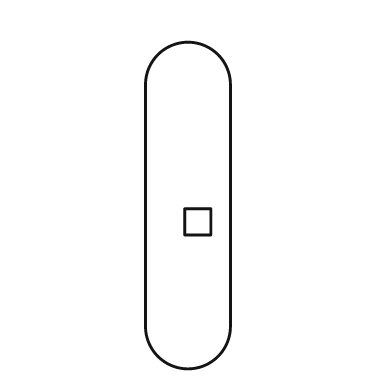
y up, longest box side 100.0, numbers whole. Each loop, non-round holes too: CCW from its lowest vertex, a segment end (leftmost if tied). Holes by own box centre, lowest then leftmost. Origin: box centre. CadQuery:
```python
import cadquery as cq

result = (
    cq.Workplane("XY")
    .moveTo(-13.0, -37.0)
    .threePointArc((0.0, -50.0), (13.0, -37.0))
    .lineTo(13.0, 37.0)
    .threePointArc((0.0, 50.0), (-13.0, 37.0))
    .close()
    .moveTo(-1.0, -9.0)
    .lineTo(7.0, -9.0)
    .lineTo(7.0, -1.0)
    .lineTo(-1.0, -1.0)
    .close()
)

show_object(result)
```